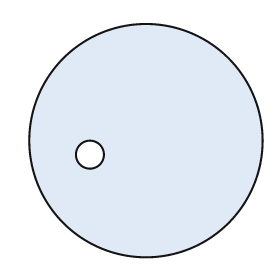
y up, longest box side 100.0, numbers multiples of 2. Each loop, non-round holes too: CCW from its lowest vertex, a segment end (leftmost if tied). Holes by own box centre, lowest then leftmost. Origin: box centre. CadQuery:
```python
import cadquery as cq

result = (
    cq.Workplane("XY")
    .moveTo(0.0, 0.0)
    .circle(50.0)
    .moveTo(-24.0, -6.0)
    .circle(6.0)
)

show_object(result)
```